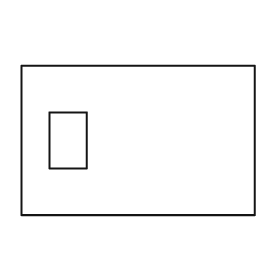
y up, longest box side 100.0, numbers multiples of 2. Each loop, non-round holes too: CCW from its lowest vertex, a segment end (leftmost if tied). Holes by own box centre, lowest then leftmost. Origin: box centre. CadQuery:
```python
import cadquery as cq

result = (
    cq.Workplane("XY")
    .moveTo(-50.0, -32.0)
    .lineTo(50.0, -32.0)
    .lineTo(50.0, 32.0)
    .lineTo(-50.0, 32.0)
    .close()
    .moveTo(-38.0, -12.0)
    .lineTo(-22.0, -12.0)
    .lineTo(-22.0, 12.0)
    .lineTo(-38.0, 12.0)
    .close()
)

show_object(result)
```